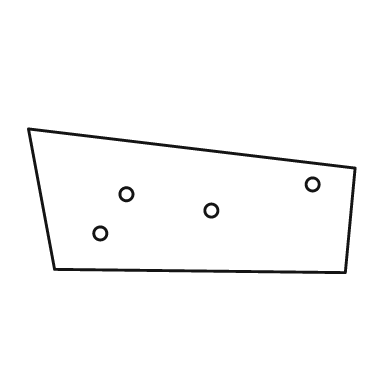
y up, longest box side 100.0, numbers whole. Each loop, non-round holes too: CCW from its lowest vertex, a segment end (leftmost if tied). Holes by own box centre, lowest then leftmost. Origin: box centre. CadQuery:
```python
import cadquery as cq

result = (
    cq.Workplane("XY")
    .moveTo(47.0, -22.0)
    .lineTo(50.0, 10.0)
    .lineTo(-50.0, 22.0)
    .lineTo(-42.0, -21.0)
    .close()
    .moveTo(-28.0, -10.0)
    .circle(2.0)
    .moveTo(6.0, -3.0)
    .circle(2.0)
    .moveTo(-20.0, 2.0)
    .circle(2.0)
    .moveTo(37.0, 5.0)
    .circle(2.0)
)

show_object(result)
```